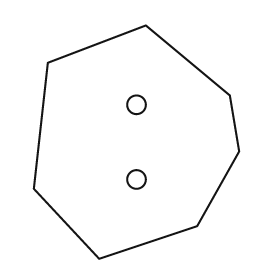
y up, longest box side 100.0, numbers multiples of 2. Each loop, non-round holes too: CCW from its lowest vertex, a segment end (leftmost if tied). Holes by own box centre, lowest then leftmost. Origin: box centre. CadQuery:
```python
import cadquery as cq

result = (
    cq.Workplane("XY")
    .moveTo(-16.0, -50.0)
    .lineTo(26.0, -36.0)
    .lineTo(44.0, -4.0)
    .lineTo(40.0, 20.0)
    .lineTo(4.0, 50.0)
    .lineTo(-38.0, 34.0)
    .lineTo(-44.0, -20.0)
    .close()
    .moveTo(0.0, -16.0)
    .circle(4.0)
    .moveTo(0.0, 16.0)
    .circle(4.0)
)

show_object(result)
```